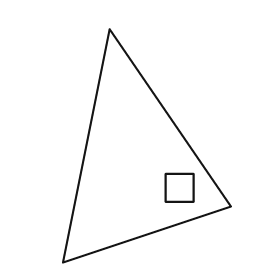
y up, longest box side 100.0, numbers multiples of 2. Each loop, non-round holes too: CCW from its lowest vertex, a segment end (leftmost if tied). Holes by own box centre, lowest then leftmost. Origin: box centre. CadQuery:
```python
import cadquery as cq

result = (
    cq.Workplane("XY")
    .moveTo(-36.0, -50.0)
    .lineTo(36.0, -26.0)
    .lineTo(-16.0, 50.0)
    .close()
    .moveTo(8.0, -24.0)
    .lineTo(20.0, -24.0)
    .lineTo(20.0, -12.0)
    .lineTo(8.0, -12.0)
    .close()
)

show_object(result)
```